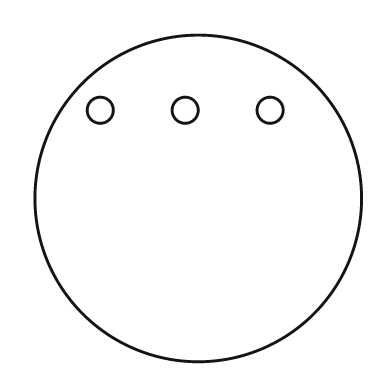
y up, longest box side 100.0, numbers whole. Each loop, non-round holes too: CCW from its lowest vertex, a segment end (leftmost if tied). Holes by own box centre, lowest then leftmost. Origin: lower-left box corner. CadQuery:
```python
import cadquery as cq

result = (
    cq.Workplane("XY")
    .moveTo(50.0, 50.0)
    .circle(50.0)
    .moveTo(20.0, 77.0)
    .circle(4.0)
    .moveTo(46.0, 77.0)
    .circle(4.0)
    .moveTo(72.0, 77.0)
    .circle(4.0)
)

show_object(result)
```